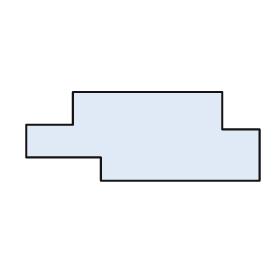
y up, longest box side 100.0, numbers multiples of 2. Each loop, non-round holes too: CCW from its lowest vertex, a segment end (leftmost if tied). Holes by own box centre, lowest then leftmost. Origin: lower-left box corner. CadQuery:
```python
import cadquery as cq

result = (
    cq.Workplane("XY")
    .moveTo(32.0, 0.0)
    .lineTo(100.0, 0.0)
    .lineTo(100.0, 22.0)
    .lineTo(84.0, 22.0)
    .lineTo(84.0, 38.0)
    .lineTo(20.0, 38.0)
    .lineTo(20.0, 24.0)
    .lineTo(0.0, 24.0)
    .lineTo(0.0, 10.0)
    .lineTo(32.0, 10.0)
    .close()
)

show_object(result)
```